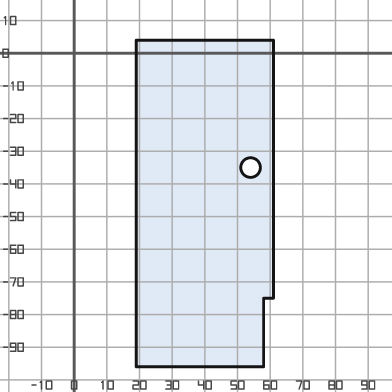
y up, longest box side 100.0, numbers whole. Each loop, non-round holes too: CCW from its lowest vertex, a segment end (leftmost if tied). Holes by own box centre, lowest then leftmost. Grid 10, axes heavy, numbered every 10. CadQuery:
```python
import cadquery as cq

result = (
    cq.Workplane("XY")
    .moveTo(19.0, -96.0)
    .lineTo(58.0, -96.0)
    .lineTo(58.0, -75.0)
    .lineTo(61.0, -75.0)
    .lineTo(61.0, 4.0)
    .lineTo(19.0, 4.0)
    .close()
    .moveTo(54.0, -35.0)
    .circle(3.0)
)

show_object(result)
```